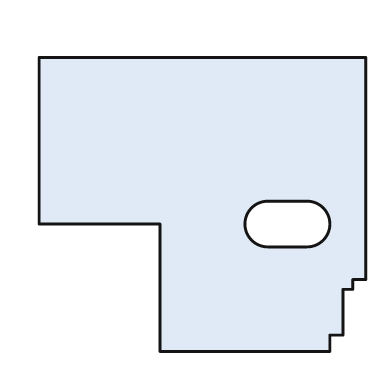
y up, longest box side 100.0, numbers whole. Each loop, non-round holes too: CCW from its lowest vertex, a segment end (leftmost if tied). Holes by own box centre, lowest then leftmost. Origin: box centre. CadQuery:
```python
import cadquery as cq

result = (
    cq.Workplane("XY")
    .moveTo(-13.0, -45.0)
    .lineTo(39.0, -45.0)
    .lineTo(39.0, -40.0)
    .lineTo(43.0, -40.0)
    .lineTo(43.0, -26.0)
    .lineTo(46.0, -26.0)
    .lineTo(46.0, -23.0)
    .lineTo(50.0, -23.0)
    .lineTo(50.0, 45.0)
    .lineTo(-50.0, 45.0)
    .lineTo(-50.0, -6.0)
    .lineTo(-13.0, -6.0)
    .close()
    .moveTo(20.0, -13.0)
    .lineTo(32.0, -13.0)
    .threePointArc((39.0, -6.0), (32.0, 1.0))
    .lineTo(20.0, 1.0)
    .threePointArc((13.0, -6.0), (20.0, -13.0))
    .close()
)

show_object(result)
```